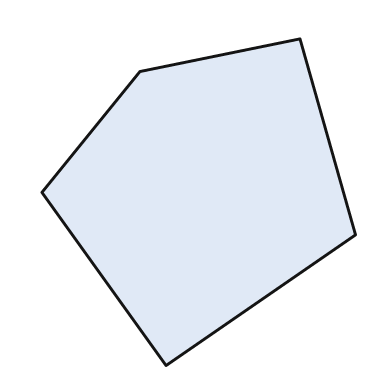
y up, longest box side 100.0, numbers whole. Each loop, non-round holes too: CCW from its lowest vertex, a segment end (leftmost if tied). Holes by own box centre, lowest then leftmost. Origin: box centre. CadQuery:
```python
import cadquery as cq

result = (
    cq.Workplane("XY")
    .moveTo(-10.0, -50.0)
    .lineTo(48.0, -10.0)
    .lineTo(31.0, 50.0)
    .lineTo(-18.0, 40.0)
    .lineTo(-48.0, 3.0)
    .close()
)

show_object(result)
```